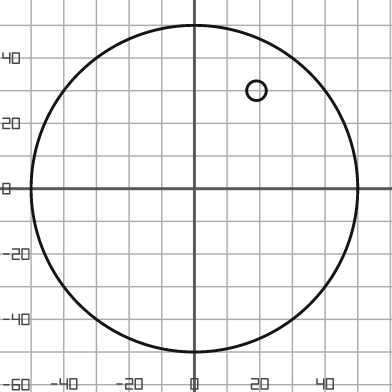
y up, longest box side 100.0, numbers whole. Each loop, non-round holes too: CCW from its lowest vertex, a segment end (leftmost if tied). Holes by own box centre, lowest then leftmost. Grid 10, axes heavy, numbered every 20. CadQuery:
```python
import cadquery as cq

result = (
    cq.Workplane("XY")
    .moveTo(0.0, 0.0)
    .circle(50.0)
    .moveTo(19.0, 30.0)
    .circle(3.0)
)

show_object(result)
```